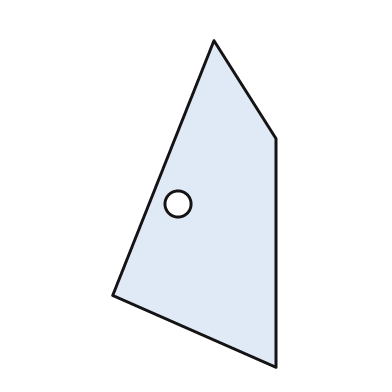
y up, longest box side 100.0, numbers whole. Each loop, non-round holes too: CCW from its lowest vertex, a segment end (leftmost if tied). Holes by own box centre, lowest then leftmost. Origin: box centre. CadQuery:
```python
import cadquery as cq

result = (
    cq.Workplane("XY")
    .moveTo(25.0, -50.0)
    .lineTo(25.0, 20.0)
    .lineTo(6.0, 50.0)
    .lineTo(-25.0, -28.0)
    .close()
    .moveTo(-5.0, 0.0)
    .circle(4.0)
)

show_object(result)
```